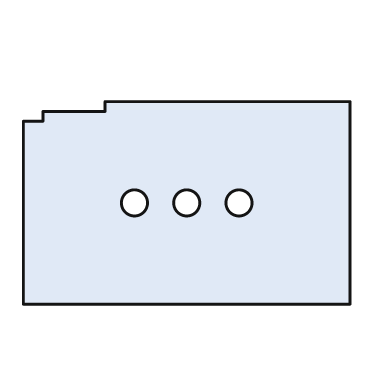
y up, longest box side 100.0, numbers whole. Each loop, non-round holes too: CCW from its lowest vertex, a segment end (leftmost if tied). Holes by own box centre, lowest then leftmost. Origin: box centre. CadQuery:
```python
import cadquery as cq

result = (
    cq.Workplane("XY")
    .moveTo(-50.0, -31.0)
    .lineTo(50.0, -31.0)
    .lineTo(50.0, 31.0)
    .lineTo(-25.0, 31.0)
    .lineTo(-25.0, 28.0)
    .lineTo(-44.0, 28.0)
    .lineTo(-44.0, 25.0)
    .lineTo(-50.0, 25.0)
    .close()
    .moveTo(-16.0, 0.0)
    .circle(4.0)
    .moveTo(0.0, 0.0)
    .circle(4.0)
    .moveTo(16.0, 0.0)
    .circle(4.0)
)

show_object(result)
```